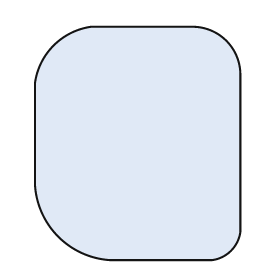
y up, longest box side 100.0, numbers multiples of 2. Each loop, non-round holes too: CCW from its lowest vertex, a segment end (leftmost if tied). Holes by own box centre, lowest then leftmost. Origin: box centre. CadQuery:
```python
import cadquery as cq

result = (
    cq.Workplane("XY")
    .moveTo(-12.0, -50.0)
    .lineTo(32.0, -50.0)
    .threePointArc((40.0, -46.0), (44.0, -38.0))
    .lineTo(44.0, 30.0)
    .threePointArc((38.0, 44.0), (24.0, 50.0))
    .lineTo(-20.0, 50.0)
    .threePointArc((-36.0, 42.0), (-44.0, 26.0))
    .lineTo(-44.0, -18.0)
    .threePointArc((-34.0, -40.0), (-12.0, -50.0))
    .close()
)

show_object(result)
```